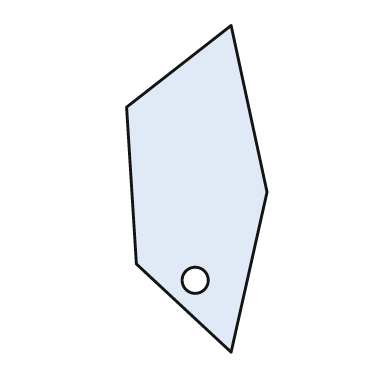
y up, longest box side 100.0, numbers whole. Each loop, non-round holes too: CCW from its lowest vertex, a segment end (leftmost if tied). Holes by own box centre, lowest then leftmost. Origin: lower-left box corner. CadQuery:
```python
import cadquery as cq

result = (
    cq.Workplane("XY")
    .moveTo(32.0, 0.0)
    .lineTo(43.0, 49.0)
    .lineTo(32.0, 100.0)
    .lineTo(0.0, 75.0)
    .lineTo(3.0, 27.0)
    .close()
    .moveTo(21.0, 22.0)
    .circle(4.0)
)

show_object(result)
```